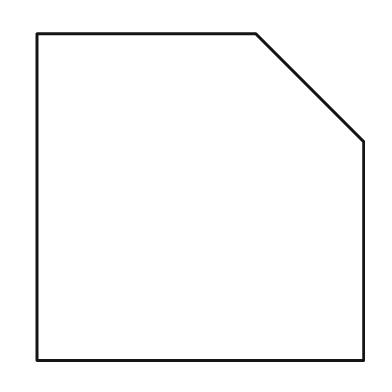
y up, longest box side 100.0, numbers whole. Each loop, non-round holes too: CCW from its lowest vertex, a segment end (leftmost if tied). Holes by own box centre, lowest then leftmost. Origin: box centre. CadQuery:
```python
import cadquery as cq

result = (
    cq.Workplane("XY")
    .moveTo(-50.0, -50.0)
    .lineTo(50.0, -50.0)
    .lineTo(50.0, 17.0)
    .lineTo(17.0, 50.0)
    .lineTo(-50.0, 50.0)
    .close()
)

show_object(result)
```